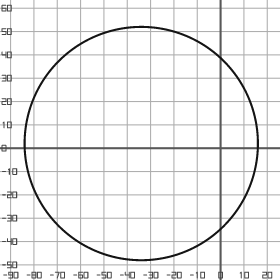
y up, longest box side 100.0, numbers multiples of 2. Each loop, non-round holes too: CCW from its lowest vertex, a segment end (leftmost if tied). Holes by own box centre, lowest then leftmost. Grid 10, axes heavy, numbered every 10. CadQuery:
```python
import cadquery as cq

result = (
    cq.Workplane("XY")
    .moveTo(-34.0, 2.0)
    .circle(50.0)
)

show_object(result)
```